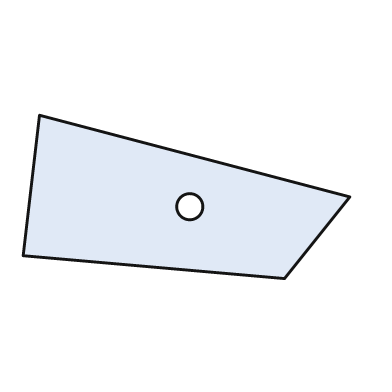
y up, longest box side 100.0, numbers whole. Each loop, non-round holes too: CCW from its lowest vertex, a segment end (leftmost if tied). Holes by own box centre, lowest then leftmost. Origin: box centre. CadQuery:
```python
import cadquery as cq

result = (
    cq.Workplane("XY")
    .moveTo(30.0, -25.0)
    .lineTo(50.0, 0.0)
    .lineTo(-45.0, 25.0)
    .lineTo(-50.0, -18.0)
    .close()
    .moveTo(1.0, -3.0)
    .circle(4.0)
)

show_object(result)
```